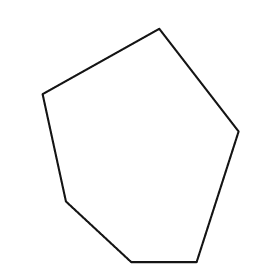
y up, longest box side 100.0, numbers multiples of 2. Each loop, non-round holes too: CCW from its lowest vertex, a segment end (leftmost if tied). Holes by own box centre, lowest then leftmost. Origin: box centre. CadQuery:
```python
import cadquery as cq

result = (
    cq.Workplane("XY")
    .moveTo(-4.0, -50.0)
    .lineTo(24.0, -50.0)
    .lineTo(42.0, 6.0)
    .lineTo(8.0, 50.0)
    .lineTo(-42.0, 22.0)
    .lineTo(-32.0, -24.0)
    .close()
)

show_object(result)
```